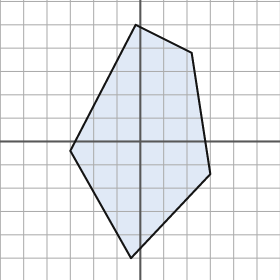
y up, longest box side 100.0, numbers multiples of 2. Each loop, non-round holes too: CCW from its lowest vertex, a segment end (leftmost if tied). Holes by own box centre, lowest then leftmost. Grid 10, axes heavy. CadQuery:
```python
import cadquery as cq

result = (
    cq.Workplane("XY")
    .moveTo(-4.0, -50.0)
    .lineTo(30.0, -14.0)
    .lineTo(22.0, 38.0)
    .lineTo(-2.0, 50.0)
    .lineTo(-30.0, -4.0)
    .close()
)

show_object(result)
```